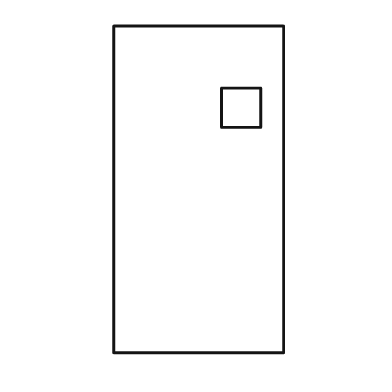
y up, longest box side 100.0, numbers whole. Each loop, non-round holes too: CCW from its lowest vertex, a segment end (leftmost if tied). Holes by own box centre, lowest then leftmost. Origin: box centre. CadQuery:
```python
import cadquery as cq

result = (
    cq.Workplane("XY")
    .moveTo(-26.0, -50.0)
    .lineTo(26.0, -50.0)
    .lineTo(26.0, 50.0)
    .lineTo(-26.0, 50.0)
    .close()
    .moveTo(7.0, 19.0)
    .lineTo(19.0, 19.0)
    .lineTo(19.0, 31.0)
    .lineTo(7.0, 31.0)
    .close()
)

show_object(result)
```